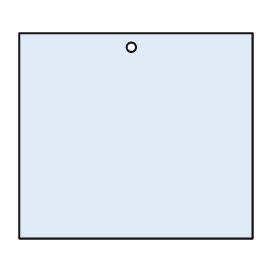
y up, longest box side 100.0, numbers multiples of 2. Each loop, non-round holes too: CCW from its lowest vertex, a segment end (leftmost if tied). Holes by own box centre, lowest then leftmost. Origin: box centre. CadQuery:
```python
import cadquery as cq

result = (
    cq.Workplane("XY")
    .moveTo(-50.0, -44.0)
    .lineTo(50.0, -44.0)
    .lineTo(50.0, 44.0)
    .lineTo(-50.0, 44.0)
    .close()
    .moveTo(-2.0, 38.0)
    .circle(2.0)
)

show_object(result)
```